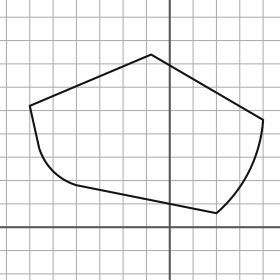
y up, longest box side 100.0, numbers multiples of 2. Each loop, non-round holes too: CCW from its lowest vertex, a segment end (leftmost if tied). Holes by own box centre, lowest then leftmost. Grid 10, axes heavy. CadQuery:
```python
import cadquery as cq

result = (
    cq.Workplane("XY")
    .moveTo(20.0, 6.0)
    .threePointArc((34.0, 24.0), (40.0, 46.0))
    .lineTo(-8.0, 74.0)
    .lineTo(-60.0, 52.0)
    .lineTo(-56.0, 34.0)
    .threePointArc((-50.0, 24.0), (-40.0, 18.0))
    .close()
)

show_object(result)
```